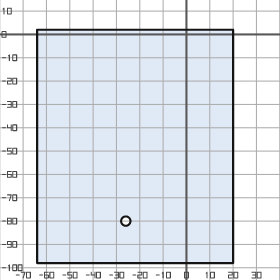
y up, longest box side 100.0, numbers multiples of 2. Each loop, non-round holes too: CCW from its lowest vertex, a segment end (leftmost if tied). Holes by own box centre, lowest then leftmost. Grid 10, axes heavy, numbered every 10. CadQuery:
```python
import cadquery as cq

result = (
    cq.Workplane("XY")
    .moveTo(-64.0, -98.0)
    .lineTo(20.0, -98.0)
    .lineTo(20.0, 2.0)
    .lineTo(-64.0, 2.0)
    .close()
    .moveTo(-26.0, -80.0)
    .circle(2.0)
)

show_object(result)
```